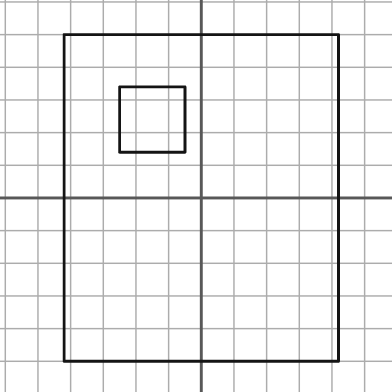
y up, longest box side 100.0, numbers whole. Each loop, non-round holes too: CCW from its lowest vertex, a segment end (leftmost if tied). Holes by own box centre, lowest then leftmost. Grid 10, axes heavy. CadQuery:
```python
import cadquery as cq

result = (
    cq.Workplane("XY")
    .moveTo(-42.0, -50.0)
    .lineTo(42.0, -50.0)
    .lineTo(42.0, 50.0)
    .lineTo(-42.0, 50.0)
    .close()
    .moveTo(-25.0, 14.0)
    .lineTo(-5.0, 14.0)
    .lineTo(-5.0, 34.0)
    .lineTo(-25.0, 34.0)
    .close()
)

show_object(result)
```